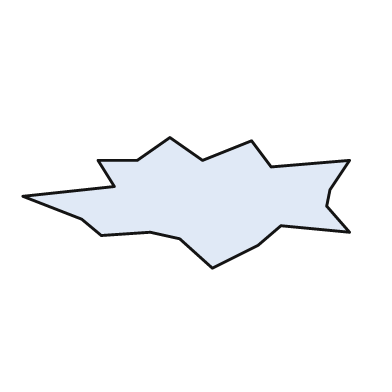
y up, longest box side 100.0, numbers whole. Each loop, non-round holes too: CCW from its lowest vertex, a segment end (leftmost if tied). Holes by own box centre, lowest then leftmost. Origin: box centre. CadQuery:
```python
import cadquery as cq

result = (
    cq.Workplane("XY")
    .moveTo(8.0, -20.0)
    .lineTo(22.0, -13.0)
    .lineTo(29.0, -7.0)
    .lineTo(50.0, -9.0)
    .lineTo(43.0, -1.0)
    .lineTo(44.0, 4.0)
    .lineTo(50.0, 13.0)
    .lineTo(26.0, 11.0)
    .lineTo(20.0, 19.0)
    .lineTo(5.0, 13.0)
    .lineTo(-5.0, 20.0)
    .lineTo(-15.0, 13.0)
    .lineTo(-27.0, 13.0)
    .lineTo(-22.0, 5.0)
    .lineTo(-50.0, 2.0)
    .lineTo(-32.0, -5.0)
    .lineTo(-26.0, -10.0)
    .lineTo(-11.0, -9.0)
    .lineTo(-2.0, -11.0)
    .close()
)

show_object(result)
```